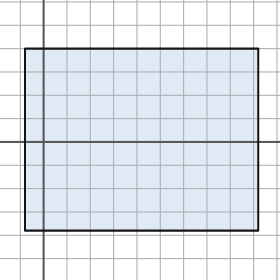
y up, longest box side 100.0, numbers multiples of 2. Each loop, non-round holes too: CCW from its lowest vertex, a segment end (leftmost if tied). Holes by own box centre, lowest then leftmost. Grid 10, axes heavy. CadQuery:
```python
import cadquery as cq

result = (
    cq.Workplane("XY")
    .moveTo(-8.0, -38.0)
    .lineTo(92.0, -38.0)
    .lineTo(92.0, 40.0)
    .lineTo(-8.0, 40.0)
    .close()
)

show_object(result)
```